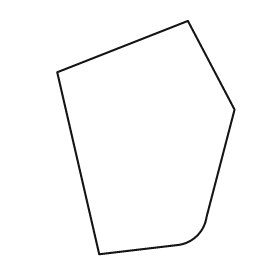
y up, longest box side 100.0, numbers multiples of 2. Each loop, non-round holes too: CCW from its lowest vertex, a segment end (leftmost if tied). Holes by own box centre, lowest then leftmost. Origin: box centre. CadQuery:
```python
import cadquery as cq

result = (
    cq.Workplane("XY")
    .moveTo(-20.0, -50.0)
    .lineTo(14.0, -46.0)
    .threePointArc((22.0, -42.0), (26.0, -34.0))
    .lineTo(38.0, 12.0)
    .lineTo(18.0, 50.0)
    .lineTo(-38.0, 28.0)
    .close()
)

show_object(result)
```